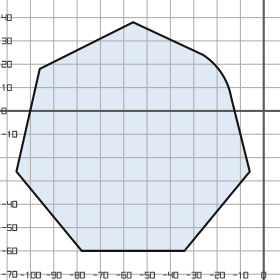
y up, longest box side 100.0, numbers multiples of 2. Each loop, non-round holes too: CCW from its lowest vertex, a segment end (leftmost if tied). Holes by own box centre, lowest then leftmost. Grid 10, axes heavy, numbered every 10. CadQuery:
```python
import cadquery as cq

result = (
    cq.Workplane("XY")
    .moveTo(-78.0, -60.0)
    .lineTo(-34.0, -60.0)
    .lineTo(-6.0, -26.0)
    .lineTo(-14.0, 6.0)
    .threePointArc((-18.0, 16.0), (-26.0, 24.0))
    .lineTo(-56.0, 38.0)
    .lineTo(-96.0, 18.0)
    .lineTo(-106.0, -26.0)
    .close()
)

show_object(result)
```